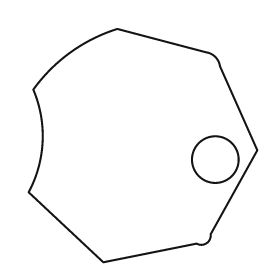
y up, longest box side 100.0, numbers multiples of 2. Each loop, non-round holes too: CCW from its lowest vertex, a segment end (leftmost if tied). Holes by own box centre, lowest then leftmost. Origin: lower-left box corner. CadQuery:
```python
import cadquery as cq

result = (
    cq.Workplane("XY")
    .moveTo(32.0, 0.0)
    .lineTo(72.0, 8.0)
    .threePointArc((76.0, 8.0), (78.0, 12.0))
    .lineTo(98.0, 48.0)
    .lineTo(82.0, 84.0)
    .threePointArc((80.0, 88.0), (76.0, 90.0))
    .lineTo(38.0, 100.0)
    .threePointArc((18.0, 90.0), (2.0, 74.0))
    .threePointArc((6.0, 52.0), (0.0, 30.0))
    .close()
    .moveTo(80.0, 44.0)
    .circle(10.0)
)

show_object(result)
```